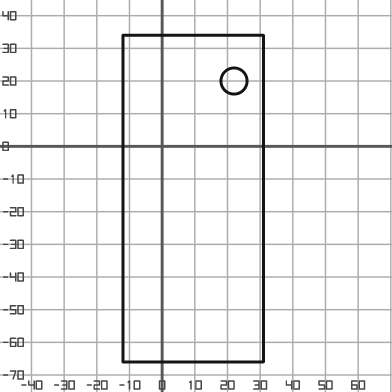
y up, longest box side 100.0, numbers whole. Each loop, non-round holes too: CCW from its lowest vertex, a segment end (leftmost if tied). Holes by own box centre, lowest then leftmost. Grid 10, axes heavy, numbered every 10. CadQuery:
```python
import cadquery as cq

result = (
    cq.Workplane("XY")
    .moveTo(-12.0, -66.0)
    .lineTo(31.0, -66.0)
    .lineTo(31.0, 34.0)
    .lineTo(-12.0, 34.0)
    .close()
    .moveTo(22.0, 20.0)
    .circle(4.0)
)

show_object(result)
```